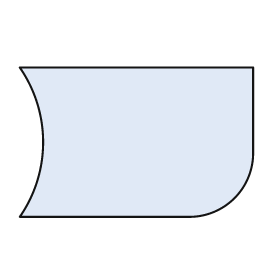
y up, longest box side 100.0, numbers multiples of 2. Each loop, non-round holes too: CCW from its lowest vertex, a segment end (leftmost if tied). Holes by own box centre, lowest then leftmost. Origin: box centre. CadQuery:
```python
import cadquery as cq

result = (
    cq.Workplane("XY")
    .moveTo(-50.0, -32.0)
    .lineTo(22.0, -32.0)
    .threePointArc((42.0, -24.0), (50.0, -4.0))
    .lineTo(50.0, 32.0)
    .lineTo(-50.0, 32.0)
    .threePointArc((-40.0, 0.0), (-50.0, -32.0))
    .close()
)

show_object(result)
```